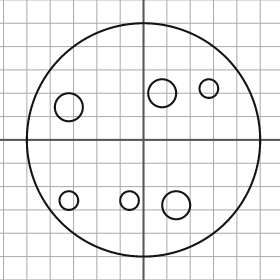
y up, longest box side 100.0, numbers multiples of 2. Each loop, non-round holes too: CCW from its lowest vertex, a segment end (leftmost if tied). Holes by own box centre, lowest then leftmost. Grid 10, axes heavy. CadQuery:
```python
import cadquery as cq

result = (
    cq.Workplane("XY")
    .moveTo(0.0, 0.0)
    .circle(50.0)
    .moveTo(14.0, -28.0)
    .circle(6.0)
    .moveTo(-32.0, -26.0)
    .circle(4.0)
    .moveTo(-6.0, -26.0)
    .circle(4.0)
    .moveTo(-32.0, 14.0)
    .circle(6.0)
    .moveTo(8.0, 20.0)
    .circle(6.0)
    .moveTo(28.0, 22.0)
    .circle(4.0)
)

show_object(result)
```